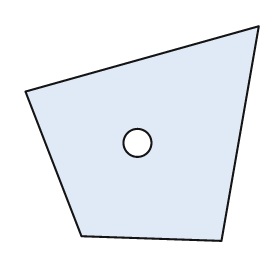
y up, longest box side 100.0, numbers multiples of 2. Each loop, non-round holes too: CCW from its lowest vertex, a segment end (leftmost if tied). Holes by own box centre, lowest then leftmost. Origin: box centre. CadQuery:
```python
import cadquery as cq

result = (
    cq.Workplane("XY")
    .moveTo(34.0, -46.0)
    .lineTo(50.0, 46.0)
    .lineTo(-50.0, 18.0)
    .lineTo(-26.0, -44.0)
    .close()
    .moveTo(-2.0, -4.0)
    .circle(6.0)
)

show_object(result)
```